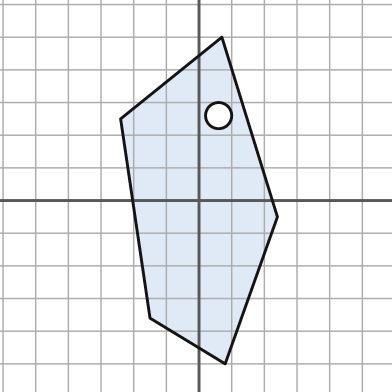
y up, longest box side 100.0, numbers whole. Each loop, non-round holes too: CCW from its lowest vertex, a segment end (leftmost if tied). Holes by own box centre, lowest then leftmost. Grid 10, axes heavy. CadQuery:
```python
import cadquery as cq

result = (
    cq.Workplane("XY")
    .moveTo(8.0, -50.0)
    .lineTo(24.0, -5.0)
    .lineTo(7.0, 50.0)
    .lineTo(-24.0, 25.0)
    .lineTo(-15.0, -36.0)
    .close()
    .moveTo(6.0, 26.0)
    .circle(4.0)
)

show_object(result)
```